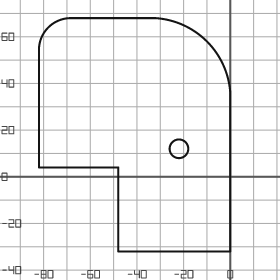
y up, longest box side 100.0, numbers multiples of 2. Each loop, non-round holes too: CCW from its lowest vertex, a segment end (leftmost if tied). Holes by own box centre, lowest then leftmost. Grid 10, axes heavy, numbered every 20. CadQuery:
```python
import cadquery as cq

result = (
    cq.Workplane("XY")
    .moveTo(-48.0, -32.0)
    .lineTo(0.0, -32.0)
    .lineTo(0.0, 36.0)
    .threePointArc((-10.0, 58.0), (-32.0, 68.0))
    .lineTo(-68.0, 68.0)
    .threePointArc((-78.0, 64.0), (-82.0, 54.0))
    .lineTo(-82.0, 4.0)
    .lineTo(-48.0, 4.0)
    .close()
    .moveTo(-22.0, 12.0)
    .circle(4.0)
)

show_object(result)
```